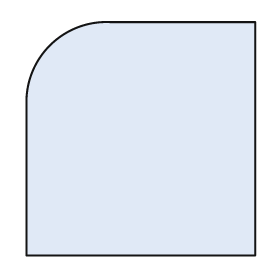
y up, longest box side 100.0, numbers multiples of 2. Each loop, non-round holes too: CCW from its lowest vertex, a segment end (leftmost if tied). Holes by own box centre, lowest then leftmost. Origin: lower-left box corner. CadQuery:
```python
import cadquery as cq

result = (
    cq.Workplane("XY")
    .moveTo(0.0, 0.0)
    .lineTo(98.0, 0.0)
    .lineTo(98.0, 100.0)
    .lineTo(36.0, 100.0)
    .threePointArc((10.0, 90.0), (0.0, 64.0))
    .close()
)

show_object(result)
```